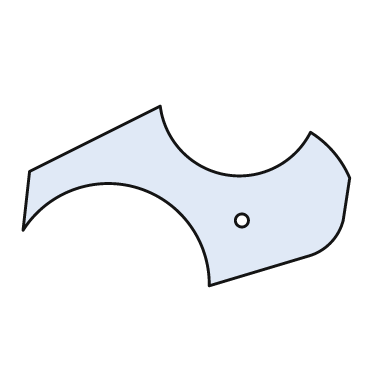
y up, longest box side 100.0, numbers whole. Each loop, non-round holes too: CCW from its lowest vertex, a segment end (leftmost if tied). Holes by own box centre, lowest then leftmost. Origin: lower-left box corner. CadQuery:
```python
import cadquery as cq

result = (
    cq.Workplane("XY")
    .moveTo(57.0, 0.0)
    .lineTo(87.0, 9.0)
    .threePointArc((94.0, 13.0), (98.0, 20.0))
    .lineTo(100.0, 33.0)
    .threePointArc((95.0, 41.0), (88.0, 47.0))
    .threePointArc((62.0, 34.0), (42.0, 55.0))
    .lineTo(2.0, 35.0)
    .lineTo(0.0, 17.0)
    .threePointArc((35.0, 30.0), (57.0, 0.0))
    .close()
    .moveTo(67.0, 20.0)
    .circle(2.0)
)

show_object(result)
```